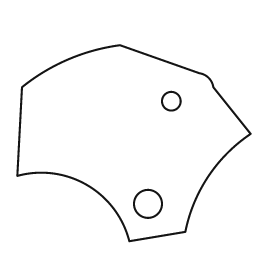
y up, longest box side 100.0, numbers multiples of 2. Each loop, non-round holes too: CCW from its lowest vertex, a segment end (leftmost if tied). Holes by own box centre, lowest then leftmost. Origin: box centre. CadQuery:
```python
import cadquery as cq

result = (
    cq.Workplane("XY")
    .moveTo(-2.0, -42.0)
    .lineTo(22.0, -38.0)
    .threePointArc((32.0, -14.0), (50.0, 4.0))
    .lineTo(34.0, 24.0)
    .threePointArc((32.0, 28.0), (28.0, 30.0))
    .lineTo(-6.0, 42.0)
    .threePointArc((-28.0, 36.0), (-48.0, 24.0))
    .lineTo(-50.0, -14.0)
    .threePointArc((-20.0, -18.0), (-2.0, -42.0))
    .close()
    .moveTo(6.0, -26.0)
    .circle(6.0)
    .moveTo(16.0, 18.0)
    .circle(4.0)
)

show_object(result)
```